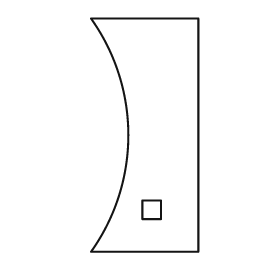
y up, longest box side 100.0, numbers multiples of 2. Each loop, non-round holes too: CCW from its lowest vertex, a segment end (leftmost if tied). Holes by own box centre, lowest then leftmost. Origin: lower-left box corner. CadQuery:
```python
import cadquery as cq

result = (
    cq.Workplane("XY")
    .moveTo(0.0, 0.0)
    .lineTo(46.0, 0.0)
    .lineTo(46.0, 100.0)
    .lineTo(0.0, 100.0)
    .threePointArc((16.0, 50.0), (0.0, 0.0))
    .close()
    .moveTo(22.0, 14.0)
    .lineTo(30.0, 14.0)
    .lineTo(30.0, 22.0)
    .lineTo(22.0, 22.0)
    .close()
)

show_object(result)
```